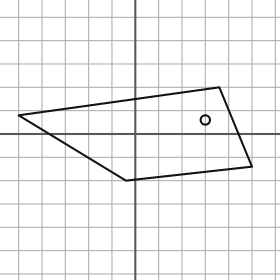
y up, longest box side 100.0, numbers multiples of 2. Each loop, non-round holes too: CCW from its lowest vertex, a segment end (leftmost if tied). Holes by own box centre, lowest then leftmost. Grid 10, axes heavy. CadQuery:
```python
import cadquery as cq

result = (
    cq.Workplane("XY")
    .moveTo(-4.0, -20.0)
    .lineTo(50.0, -14.0)
    .lineTo(36.0, 20.0)
    .lineTo(-50.0, 8.0)
    .close()
    .moveTo(30.0, 6.0)
    .circle(2.0)
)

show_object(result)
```